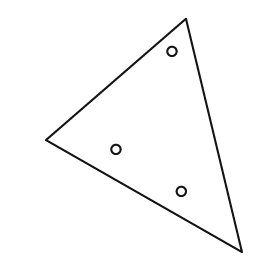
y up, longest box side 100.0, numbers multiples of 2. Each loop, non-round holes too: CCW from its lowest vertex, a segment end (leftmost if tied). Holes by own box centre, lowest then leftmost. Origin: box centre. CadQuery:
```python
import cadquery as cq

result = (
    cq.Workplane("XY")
    .moveTo(42.0, -50.0)
    .lineTo(18.0, 50.0)
    .lineTo(-42.0, -2.0)
    .close()
    .moveTo(16.0, -24.0)
    .circle(2.0)
    .moveTo(-12.0, -6.0)
    .circle(2.0)
    .moveTo(12.0, 36.0)
    .circle(2.0)
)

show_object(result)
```